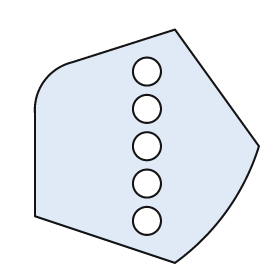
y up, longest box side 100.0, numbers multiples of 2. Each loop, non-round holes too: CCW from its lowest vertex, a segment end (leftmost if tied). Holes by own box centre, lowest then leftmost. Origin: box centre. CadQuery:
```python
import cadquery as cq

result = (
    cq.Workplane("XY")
    .moveTo(12.0, -50.0)
    .threePointArc((34.0, -28.0), (48.0, 0.0))
    .lineTo(12.0, 50.0)
    .lineTo(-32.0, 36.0)
    .threePointArc((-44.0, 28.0), (-48.0, 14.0))
    .lineTo(-48.0, -30.0)
    .close()
    .moveTo(0.0, -32.0)
    .circle(6.0)
    .moveTo(0.0, -16.0)
    .circle(6.0)
    .moveTo(0.0, 0.0)
    .circle(6.0)
    .moveTo(0.0, 16.0)
    .circle(6.0)
    .moveTo(0.0, 32.0)
    .circle(6.0)
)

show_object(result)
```